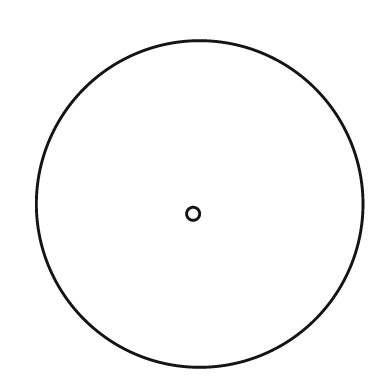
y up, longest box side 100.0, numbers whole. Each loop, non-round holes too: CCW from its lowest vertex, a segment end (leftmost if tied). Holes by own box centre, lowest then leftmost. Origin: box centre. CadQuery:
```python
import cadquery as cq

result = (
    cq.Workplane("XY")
    .moveTo(0.0, 0.0)
    .circle(50.0)
    .moveTo(-2.0, -3.0)
    .circle(2.0)
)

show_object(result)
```